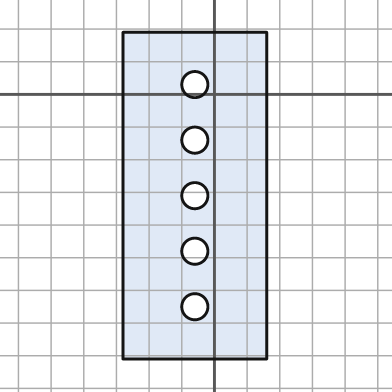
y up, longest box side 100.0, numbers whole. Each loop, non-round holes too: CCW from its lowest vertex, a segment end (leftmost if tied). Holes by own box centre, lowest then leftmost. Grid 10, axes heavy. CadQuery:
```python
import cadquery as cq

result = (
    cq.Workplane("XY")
    .moveTo(-28.0, -81.0)
    .lineTo(16.0, -81.0)
    .lineTo(16.0, 19.0)
    .lineTo(-28.0, 19.0)
    .close()
    .moveTo(-6.0, -65.0)
    .circle(4.0)
    .moveTo(-6.0, -48.0)
    .circle(4.0)
    .moveTo(-6.0, -31.0)
    .circle(4.0)
    .moveTo(-6.0, -14.0)
    .circle(4.0)
    .moveTo(-6.0, 3.0)
    .circle(4.0)
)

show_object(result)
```